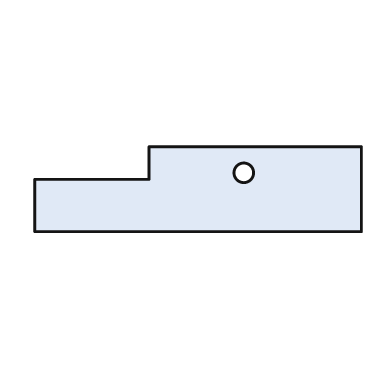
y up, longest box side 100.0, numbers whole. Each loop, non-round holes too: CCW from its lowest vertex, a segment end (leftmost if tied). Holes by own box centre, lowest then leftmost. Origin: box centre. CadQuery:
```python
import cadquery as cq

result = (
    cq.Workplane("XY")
    .moveTo(-50.0, -13.0)
    .lineTo(50.0, -13.0)
    .lineTo(50.0, 13.0)
    .lineTo(-15.0, 13.0)
    .lineTo(-15.0, 3.0)
    .lineTo(-50.0, 3.0)
    .close()
    .moveTo(14.0, 5.0)
    .circle(3.0)
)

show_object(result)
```